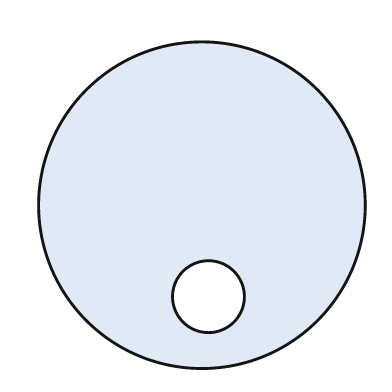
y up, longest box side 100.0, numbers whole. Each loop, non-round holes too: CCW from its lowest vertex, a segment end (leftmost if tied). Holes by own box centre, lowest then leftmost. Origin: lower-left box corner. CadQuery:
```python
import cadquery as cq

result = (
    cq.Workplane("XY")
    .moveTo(50.0, 50.0)
    .circle(50.0)
    .moveTo(52.0, 22.0)
    .circle(11.0)
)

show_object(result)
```